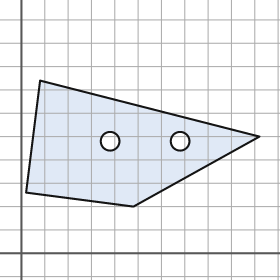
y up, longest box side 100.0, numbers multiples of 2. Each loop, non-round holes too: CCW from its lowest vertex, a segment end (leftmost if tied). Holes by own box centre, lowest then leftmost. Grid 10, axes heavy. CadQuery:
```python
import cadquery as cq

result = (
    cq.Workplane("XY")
    .moveTo(48.0, 20.0)
    .lineTo(102.0, 50.0)
    .lineTo(8.0, 74.0)
    .lineTo(2.0, 26.0)
    .close()
    .moveTo(38.0, 48.0)
    .circle(4.0)
    .moveTo(68.0, 48.0)
    .circle(4.0)
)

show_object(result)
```